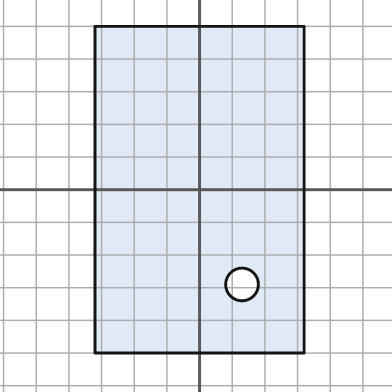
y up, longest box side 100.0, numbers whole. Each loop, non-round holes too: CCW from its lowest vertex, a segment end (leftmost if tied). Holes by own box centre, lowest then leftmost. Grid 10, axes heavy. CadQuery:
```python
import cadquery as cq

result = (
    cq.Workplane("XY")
    .moveTo(-32.0, -50.0)
    .lineTo(32.0, -50.0)
    .lineTo(32.0, 50.0)
    .lineTo(-32.0, 50.0)
    .close()
    .moveTo(13.0, -29.0)
    .circle(5.0)
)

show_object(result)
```